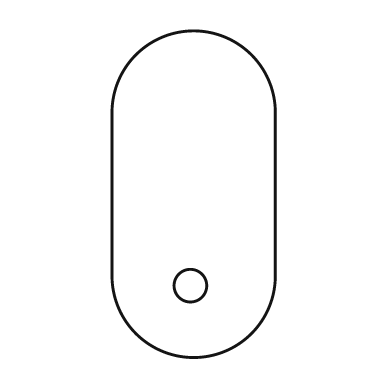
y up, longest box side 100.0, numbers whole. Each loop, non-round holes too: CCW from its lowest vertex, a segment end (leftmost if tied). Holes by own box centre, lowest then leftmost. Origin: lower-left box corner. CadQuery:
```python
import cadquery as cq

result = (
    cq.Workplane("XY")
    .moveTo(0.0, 25.0)
    .threePointArc((25.0, 0.0), (50.0, 25.0))
    .lineTo(50.0, 75.0)
    .threePointArc((25.0, 100.0), (0.0, 75.0))
    .close()
    .moveTo(24.0, 22.0)
    .circle(5.0)
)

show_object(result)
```